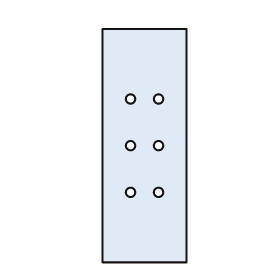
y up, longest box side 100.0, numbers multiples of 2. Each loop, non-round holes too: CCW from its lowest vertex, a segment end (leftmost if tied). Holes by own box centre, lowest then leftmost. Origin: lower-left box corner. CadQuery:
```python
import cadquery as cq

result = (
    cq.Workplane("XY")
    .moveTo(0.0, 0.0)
    .lineTo(36.0, 0.0)
    .lineTo(36.0, 100.0)
    .lineTo(0.0, 100.0)
    .close()
    .moveTo(12.0, 30.0)
    .circle(2.0)
    .moveTo(24.0, 30.0)
    .circle(2.0)
    .moveTo(12.0, 50.0)
    .circle(2.0)
    .moveTo(24.0, 50.0)
    .circle(2.0)
    .moveTo(12.0, 70.0)
    .circle(2.0)
    .moveTo(24.0, 70.0)
    .circle(2.0)
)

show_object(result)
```